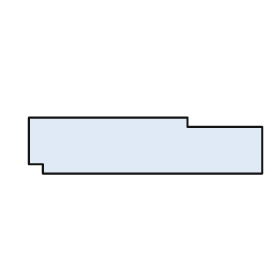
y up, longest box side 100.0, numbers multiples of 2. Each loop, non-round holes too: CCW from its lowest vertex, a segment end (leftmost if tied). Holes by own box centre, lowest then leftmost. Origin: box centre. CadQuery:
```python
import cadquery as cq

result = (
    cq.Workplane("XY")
    .moveTo(-44.0, -12.0)
    .lineTo(50.0, -12.0)
    .lineTo(50.0, 8.0)
    .lineTo(18.0, 8.0)
    .lineTo(18.0, 12.0)
    .lineTo(-50.0, 12.0)
    .lineTo(-50.0, -8.0)
    .lineTo(-44.0, -8.0)
    .close()
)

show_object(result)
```